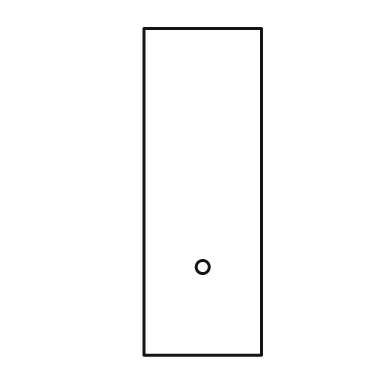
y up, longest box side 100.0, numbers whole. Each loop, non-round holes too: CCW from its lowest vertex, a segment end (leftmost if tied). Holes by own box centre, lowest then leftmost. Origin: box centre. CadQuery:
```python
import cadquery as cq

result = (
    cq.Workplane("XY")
    .moveTo(-18.0, -50.0)
    .lineTo(18.0, -50.0)
    .lineTo(18.0, 50.0)
    .lineTo(-18.0, 50.0)
    .close()
    .moveTo(0.0, -23.0)
    .circle(2.0)
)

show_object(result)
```